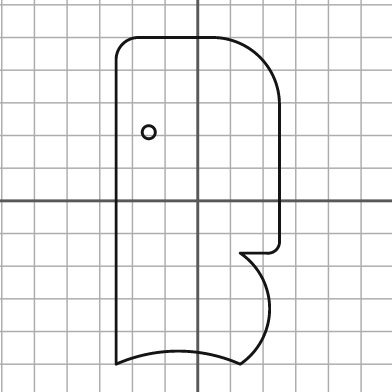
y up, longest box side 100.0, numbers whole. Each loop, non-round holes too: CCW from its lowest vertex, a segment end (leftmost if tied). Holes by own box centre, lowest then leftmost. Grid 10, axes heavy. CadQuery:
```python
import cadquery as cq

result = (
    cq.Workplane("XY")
    .moveTo(-25.0, -50.0)
    .threePointArc((-6.0, -46.0), (13.0, -50.0))
    .threePointArc((22.0, -33.0), (13.0, -16.0))
    .lineTo(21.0, -16.0)
    .threePointArc((24.0, -15.0), (25.0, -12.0))
    .lineTo(25.0, 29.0)
    .threePointArc((19.0, 44.0), (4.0, 50.0))
    .lineTo(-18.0, 50.0)
    .threePointArc((-23.0, 48.0), (-25.0, 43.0))
    .close()
    .moveTo(-15.0, 21.0)
    .circle(2.0)
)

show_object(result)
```